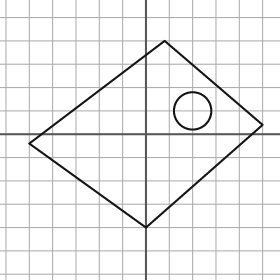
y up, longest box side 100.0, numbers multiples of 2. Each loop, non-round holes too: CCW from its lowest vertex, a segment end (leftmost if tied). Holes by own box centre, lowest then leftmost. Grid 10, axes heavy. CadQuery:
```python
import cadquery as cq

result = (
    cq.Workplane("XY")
    .moveTo(0.0, -40.0)
    .lineTo(50.0, 4.0)
    .lineTo(8.0, 40.0)
    .lineTo(-50.0, -4.0)
    .close()
    .moveTo(20.0, 10.0)
    .circle(8.0)
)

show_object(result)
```